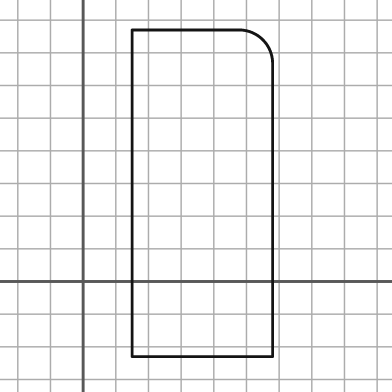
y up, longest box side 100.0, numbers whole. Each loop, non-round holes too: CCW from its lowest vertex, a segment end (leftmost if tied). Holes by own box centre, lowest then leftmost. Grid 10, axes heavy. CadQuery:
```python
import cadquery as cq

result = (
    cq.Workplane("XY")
    .moveTo(15.0, -23.0)
    .lineTo(58.0, -23.0)
    .lineTo(58.0, 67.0)
    .threePointArc((55.0, 74.0), (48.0, 77.0))
    .lineTo(15.0, 77.0)
    .close()
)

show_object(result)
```